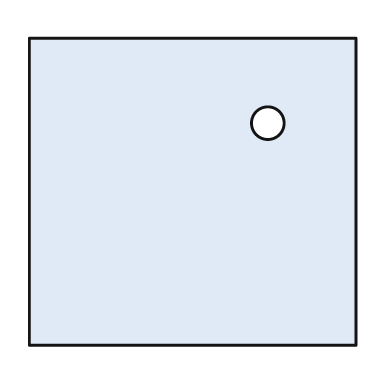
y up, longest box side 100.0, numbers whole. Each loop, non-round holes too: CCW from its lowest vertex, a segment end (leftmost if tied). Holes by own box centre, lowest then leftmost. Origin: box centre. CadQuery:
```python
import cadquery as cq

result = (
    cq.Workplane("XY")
    .moveTo(-50.0, -47.0)
    .lineTo(50.0, -47.0)
    .lineTo(50.0, 47.0)
    .lineTo(-50.0, 47.0)
    .close()
    .moveTo(23.0, 21.0)
    .circle(5.0)
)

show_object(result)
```